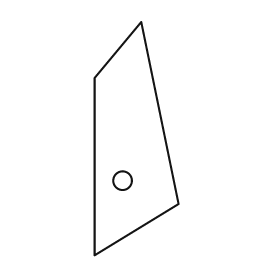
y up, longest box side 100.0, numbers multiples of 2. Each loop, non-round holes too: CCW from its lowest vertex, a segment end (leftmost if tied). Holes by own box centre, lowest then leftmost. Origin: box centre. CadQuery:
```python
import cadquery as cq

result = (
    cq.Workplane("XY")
    .moveTo(-18.0, -50.0)
    .lineTo(18.0, -28.0)
    .lineTo(2.0, 50.0)
    .lineTo(-18.0, 26.0)
    .close()
    .moveTo(-6.0, -18.0)
    .circle(4.0)
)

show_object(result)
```